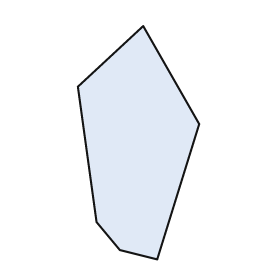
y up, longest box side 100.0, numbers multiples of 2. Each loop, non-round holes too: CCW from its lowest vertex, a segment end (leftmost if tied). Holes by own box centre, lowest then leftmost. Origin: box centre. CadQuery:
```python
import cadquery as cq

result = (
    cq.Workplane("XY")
    .moveTo(8.0, -50.0)
    .lineTo(26.0, 8.0)
    .lineTo(2.0, 50.0)
    .lineTo(-26.0, 24.0)
    .lineTo(-18.0, -34.0)
    .lineTo(-8.0, -46.0)
    .close()
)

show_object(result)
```